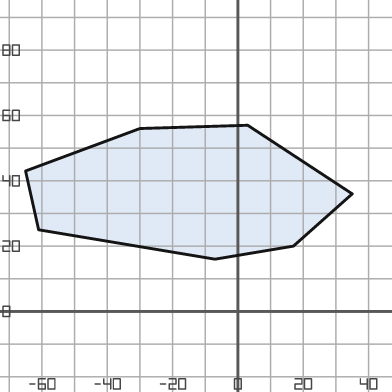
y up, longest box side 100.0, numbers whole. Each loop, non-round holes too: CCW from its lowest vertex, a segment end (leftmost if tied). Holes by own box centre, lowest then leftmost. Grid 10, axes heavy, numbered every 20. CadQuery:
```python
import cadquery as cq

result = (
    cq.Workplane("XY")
    .moveTo(-7.0, 16.0)
    .lineTo(17.0, 20.0)
    .lineTo(35.0, 36.0)
    .lineTo(3.0, 57.0)
    .lineTo(-30.0, 56.0)
    .lineTo(-65.0, 43.0)
    .lineTo(-61.0, 25.0)
    .close()
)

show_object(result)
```